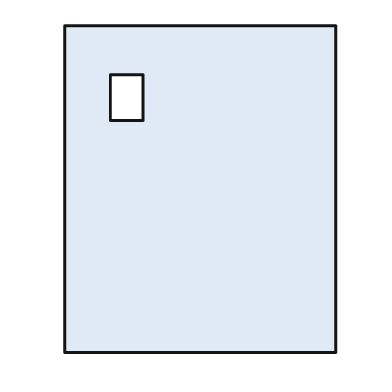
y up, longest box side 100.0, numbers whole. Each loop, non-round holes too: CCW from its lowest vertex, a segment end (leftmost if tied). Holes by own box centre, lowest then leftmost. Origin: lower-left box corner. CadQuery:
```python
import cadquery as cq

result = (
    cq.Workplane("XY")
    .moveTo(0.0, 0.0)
    .lineTo(83.0, 0.0)
    .lineTo(83.0, 100.0)
    .lineTo(0.0, 100.0)
    .close()
    .moveTo(14.0, 71.0)
    .lineTo(24.0, 71.0)
    .lineTo(24.0, 85.0)
    .lineTo(14.0, 85.0)
    .close()
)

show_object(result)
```